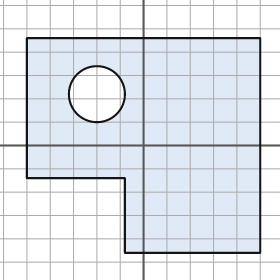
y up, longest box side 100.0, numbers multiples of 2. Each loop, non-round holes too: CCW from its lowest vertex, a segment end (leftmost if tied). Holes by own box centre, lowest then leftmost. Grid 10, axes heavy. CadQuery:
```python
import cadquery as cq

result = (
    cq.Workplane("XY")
    .moveTo(-8.0, -46.0)
    .lineTo(50.0, -46.0)
    .lineTo(50.0, 46.0)
    .lineTo(-50.0, 46.0)
    .lineTo(-50.0, -14.0)
    .lineTo(-8.0, -14.0)
    .close()
    .moveTo(-20.0, 22.0)
    .circle(12.0)
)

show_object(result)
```